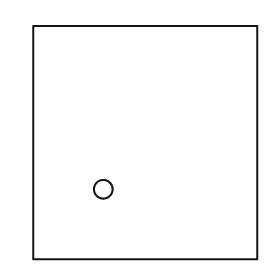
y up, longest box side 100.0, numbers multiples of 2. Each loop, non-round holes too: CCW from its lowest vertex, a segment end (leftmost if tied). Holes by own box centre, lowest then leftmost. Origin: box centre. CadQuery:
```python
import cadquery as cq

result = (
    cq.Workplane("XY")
    .moveTo(-48.0, -50.0)
    .lineTo(48.0, -50.0)
    .lineTo(48.0, 50.0)
    .lineTo(-48.0, 50.0)
    .close()
    .moveTo(-18.0, -20.0)
    .circle(4.0)
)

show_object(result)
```